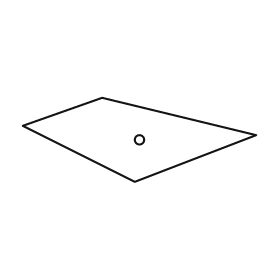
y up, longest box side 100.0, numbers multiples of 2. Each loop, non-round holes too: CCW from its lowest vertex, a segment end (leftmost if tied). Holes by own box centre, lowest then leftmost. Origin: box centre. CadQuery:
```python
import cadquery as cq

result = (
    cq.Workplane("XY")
    .moveTo(-2.0, -18.0)
    .lineTo(50.0, 2.0)
    .lineTo(-16.0, 18.0)
    .lineTo(-50.0, 6.0)
    .close()
    .moveTo(0.0, 0.0)
    .circle(2.0)
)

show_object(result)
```